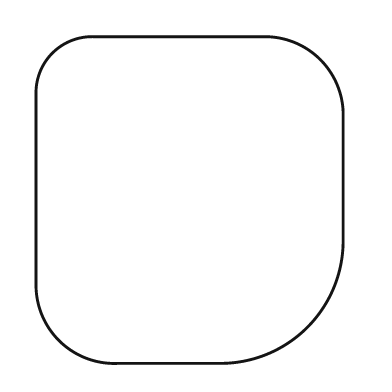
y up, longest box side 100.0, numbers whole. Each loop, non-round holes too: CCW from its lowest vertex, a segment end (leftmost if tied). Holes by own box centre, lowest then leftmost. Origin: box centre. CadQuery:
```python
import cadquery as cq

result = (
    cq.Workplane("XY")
    .moveTo(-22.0, -50.0)
    .lineTo(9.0, -50.0)
    .threePointArc((36.0, -39.0), (47.0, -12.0))
    .lineTo(47.0, 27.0)
    .threePointArc((40.0, 43.0), (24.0, 50.0))
    .lineTo(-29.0, 50.0)
    .threePointArc((-42.0, 45.0), (-47.0, 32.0))
    .lineTo(-47.0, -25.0)
    .threePointArc((-40.0, -43.0), (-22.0, -50.0))
    .close()
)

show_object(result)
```